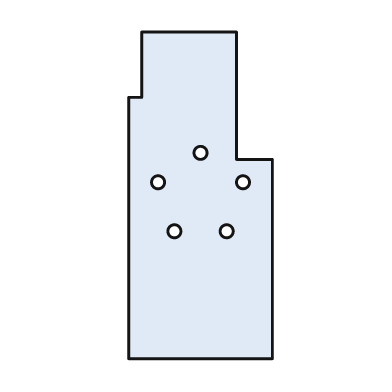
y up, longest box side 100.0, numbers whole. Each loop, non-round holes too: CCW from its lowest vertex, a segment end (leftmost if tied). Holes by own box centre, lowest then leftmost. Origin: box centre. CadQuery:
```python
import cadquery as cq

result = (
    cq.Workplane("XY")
    .moveTo(-22.0, -50.0)
    .lineTo(22.0, -50.0)
    .lineTo(22.0, 11.0)
    .lineTo(11.0, 11.0)
    .lineTo(11.0, 50.0)
    .lineTo(-18.0, 50.0)
    .lineTo(-18.0, 30.0)
    .lineTo(-22.0, 30.0)
    .close()
    .moveTo(-8.0, -11.0)
    .circle(2.0)
    .moveTo(8.0, -11.0)
    .circle(2.0)
    .moveTo(-13.0, 4.0)
    .circle(2.0)
    .moveTo(13.0, 4.0)
    .circle(2.0)
    .moveTo(0.0, 13.0)
    .circle(2.0)
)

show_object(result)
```